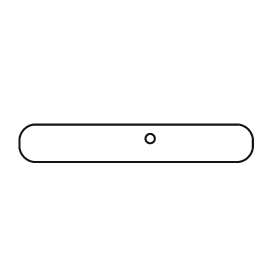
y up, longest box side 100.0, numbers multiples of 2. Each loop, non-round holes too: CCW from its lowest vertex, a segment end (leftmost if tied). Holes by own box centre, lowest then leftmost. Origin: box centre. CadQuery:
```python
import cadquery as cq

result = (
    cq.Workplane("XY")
    .moveTo(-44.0, -8.0)
    .lineTo(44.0, -8.0)
    .threePointArc((48.0, -6.0), (50.0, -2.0))
    .lineTo(50.0, 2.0)
    .threePointArc((48.0, 6.0), (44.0, 8.0))
    .lineTo(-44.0, 8.0)
    .threePointArc((-48.0, 6.0), (-50.0, 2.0))
    .lineTo(-50.0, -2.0)
    .threePointArc((-48.0, -6.0), (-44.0, -8.0))
    .close()
    .moveTo(6.0, 2.0)
    .circle(2.0)
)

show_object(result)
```